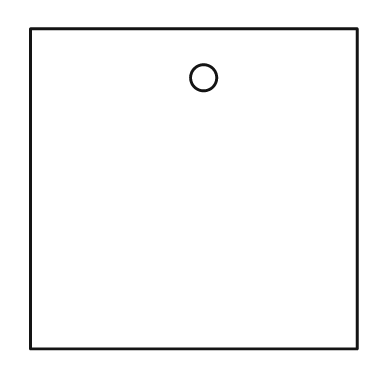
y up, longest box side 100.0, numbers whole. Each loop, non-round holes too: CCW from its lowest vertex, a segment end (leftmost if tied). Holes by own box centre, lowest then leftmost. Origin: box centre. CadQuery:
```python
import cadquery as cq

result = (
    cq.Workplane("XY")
    .moveTo(-50.0, -49.0)
    .lineTo(50.0, -49.0)
    .lineTo(50.0, 49.0)
    .lineTo(-50.0, 49.0)
    .close()
    .moveTo(3.0, 34.0)
    .circle(4.0)
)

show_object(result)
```